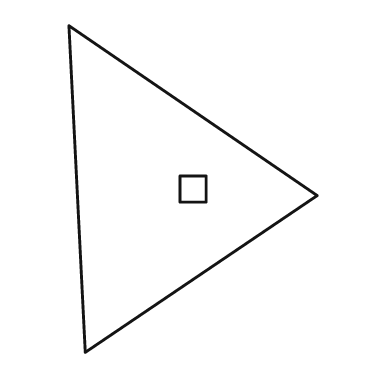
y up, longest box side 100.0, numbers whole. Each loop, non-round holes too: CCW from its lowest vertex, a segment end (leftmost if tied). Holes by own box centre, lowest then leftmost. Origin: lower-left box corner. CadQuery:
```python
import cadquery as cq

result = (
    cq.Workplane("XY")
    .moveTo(5.0, 0.0)
    .lineTo(76.0, 48.0)
    .lineTo(0.0, 100.0)
    .close()
    .moveTo(34.0, 46.0)
    .lineTo(42.0, 46.0)
    .lineTo(42.0, 54.0)
    .lineTo(34.0, 54.0)
    .close()
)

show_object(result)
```